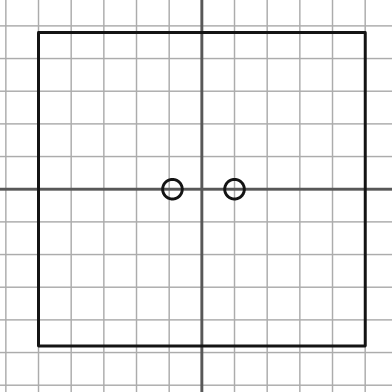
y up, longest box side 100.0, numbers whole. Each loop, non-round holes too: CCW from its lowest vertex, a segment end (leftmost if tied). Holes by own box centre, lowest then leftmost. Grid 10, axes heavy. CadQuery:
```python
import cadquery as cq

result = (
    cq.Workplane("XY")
    .moveTo(-50.0, -48.0)
    .lineTo(50.0, -48.0)
    .lineTo(50.0, 48.0)
    .lineTo(-50.0, 48.0)
    .close()
    .moveTo(-9.0, 0.0)
    .circle(3.0)
    .moveTo(10.0, 0.0)
    .circle(3.0)
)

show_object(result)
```